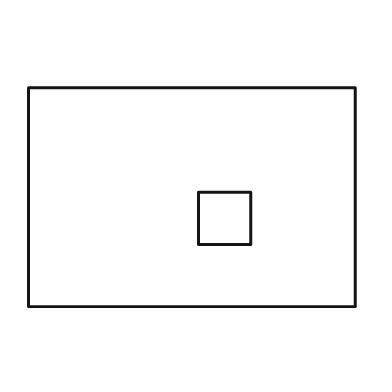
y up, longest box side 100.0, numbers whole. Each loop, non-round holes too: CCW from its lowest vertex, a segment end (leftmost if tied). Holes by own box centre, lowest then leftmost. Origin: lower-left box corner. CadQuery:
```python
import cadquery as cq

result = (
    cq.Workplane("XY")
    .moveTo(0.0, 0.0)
    .lineTo(100.0, 0.0)
    .lineTo(100.0, 67.0)
    .lineTo(0.0, 67.0)
    .close()
    .moveTo(52.0, 19.0)
    .lineTo(68.0, 19.0)
    .lineTo(68.0, 35.0)
    .lineTo(52.0, 35.0)
    .close()
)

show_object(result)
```